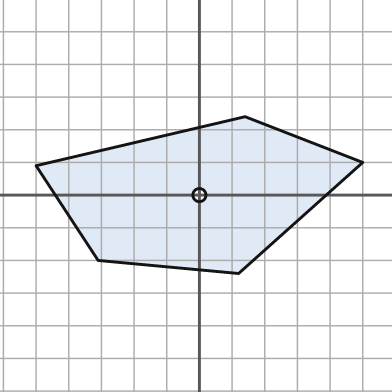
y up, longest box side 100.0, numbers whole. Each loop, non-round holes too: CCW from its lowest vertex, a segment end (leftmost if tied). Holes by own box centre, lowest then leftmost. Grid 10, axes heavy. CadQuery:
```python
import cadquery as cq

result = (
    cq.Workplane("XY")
    .moveTo(12.0, -24.0)
    .lineTo(50.0, 10.0)
    .lineTo(14.0, 24.0)
    .lineTo(-50.0, 9.0)
    .lineTo(-31.0, -20.0)
    .close()
    .moveTo(0.0, 0.0)
    .circle(2.0)
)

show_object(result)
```